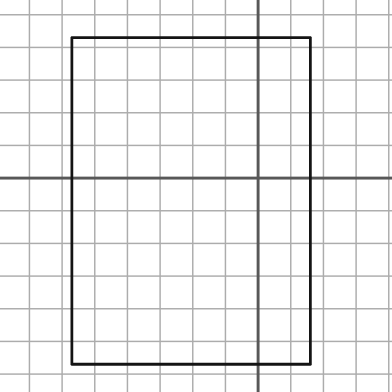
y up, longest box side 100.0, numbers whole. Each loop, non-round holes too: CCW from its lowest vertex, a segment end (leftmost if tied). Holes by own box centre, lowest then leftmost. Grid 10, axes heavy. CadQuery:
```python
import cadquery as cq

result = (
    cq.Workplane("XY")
    .moveTo(-57.0, -57.0)
    .lineTo(16.0, -57.0)
    .lineTo(16.0, 43.0)
    .lineTo(-57.0, 43.0)
    .close()
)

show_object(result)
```